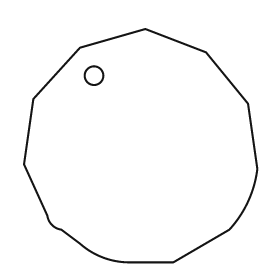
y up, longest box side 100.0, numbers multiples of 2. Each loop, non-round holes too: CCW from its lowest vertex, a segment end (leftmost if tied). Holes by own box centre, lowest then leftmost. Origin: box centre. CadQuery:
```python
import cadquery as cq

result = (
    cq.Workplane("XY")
    .moveTo(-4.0, -50.0)
    .lineTo(14.0, -50.0)
    .lineTo(38.0, -36.0)
    .threePointArc((46.0, -24.0), (50.0, -10.0))
    .lineTo(46.0, 18.0)
    .lineTo(28.0, 40.0)
    .lineTo(2.0, 50.0)
    .lineTo(-26.0, 42.0)
    .lineTo(-46.0, 20.0)
    .lineTo(-50.0, -8.0)
    .lineTo(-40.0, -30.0)
    .threePointArc((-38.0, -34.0), (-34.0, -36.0))
    .lineTo(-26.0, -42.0)
    .threePointArc((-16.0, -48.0), (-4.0, -50.0))
    .close()
    .moveTo(-20.0, 30.0)
    .circle(4.0)
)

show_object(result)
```